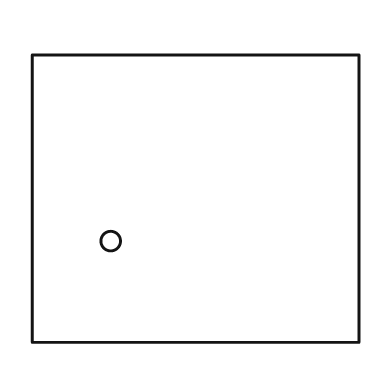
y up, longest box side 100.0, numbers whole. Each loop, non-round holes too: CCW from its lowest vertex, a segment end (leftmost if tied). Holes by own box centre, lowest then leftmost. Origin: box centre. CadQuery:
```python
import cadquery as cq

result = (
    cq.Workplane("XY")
    .moveTo(-50.0, -44.0)
    .lineTo(50.0, -44.0)
    .lineTo(50.0, 44.0)
    .lineTo(-50.0, 44.0)
    .close()
    .moveTo(-26.0, -13.0)
    .circle(3.0)
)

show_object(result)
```